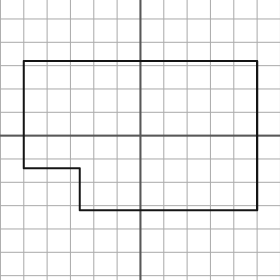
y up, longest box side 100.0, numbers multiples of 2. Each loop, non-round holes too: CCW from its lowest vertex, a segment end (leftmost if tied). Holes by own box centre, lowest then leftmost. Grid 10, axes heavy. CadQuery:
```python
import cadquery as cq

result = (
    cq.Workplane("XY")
    .moveTo(-26.0, -32.0)
    .lineTo(50.0, -32.0)
    .lineTo(50.0, 32.0)
    .lineTo(-50.0, 32.0)
    .lineTo(-50.0, -14.0)
    .lineTo(-26.0, -14.0)
    .close()
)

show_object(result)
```